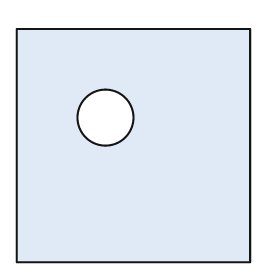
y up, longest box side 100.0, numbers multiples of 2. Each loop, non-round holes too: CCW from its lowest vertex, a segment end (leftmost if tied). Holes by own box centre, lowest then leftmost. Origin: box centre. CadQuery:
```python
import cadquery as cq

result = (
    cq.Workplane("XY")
    .moveTo(-50.0, -50.0)
    .lineTo(50.0, -50.0)
    .lineTo(50.0, 50.0)
    .lineTo(-50.0, 50.0)
    .close()
    .moveTo(-12.0, 12.0)
    .circle(12.0)
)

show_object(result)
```